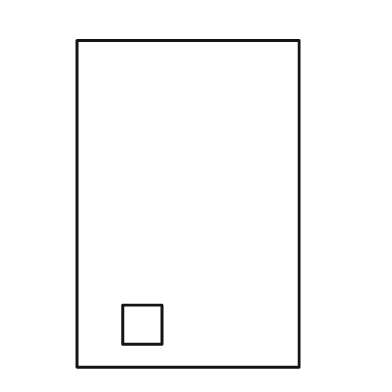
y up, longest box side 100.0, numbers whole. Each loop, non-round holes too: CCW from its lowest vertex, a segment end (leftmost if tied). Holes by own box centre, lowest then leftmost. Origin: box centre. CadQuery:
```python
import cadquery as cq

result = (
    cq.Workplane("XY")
    .moveTo(-34.0, -50.0)
    .lineTo(34.0, -50.0)
    .lineTo(34.0, 50.0)
    .lineTo(-34.0, 50.0)
    .close()
    .moveTo(-20.0, -43.0)
    .lineTo(-8.0, -43.0)
    .lineTo(-8.0, -31.0)
    .lineTo(-20.0, -31.0)
    .close()
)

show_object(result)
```